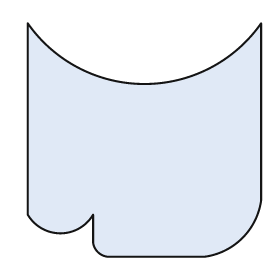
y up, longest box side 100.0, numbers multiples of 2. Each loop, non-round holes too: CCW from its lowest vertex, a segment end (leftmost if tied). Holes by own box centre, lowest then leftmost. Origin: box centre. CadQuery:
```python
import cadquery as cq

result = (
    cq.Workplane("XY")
    .moveTo(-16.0, -50.0)
    .lineTo(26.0, -50.0)
    .threePointArc((42.0, -42.0), (50.0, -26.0))
    .lineTo(50.0, 50.0)
    .threePointArc((0.0, 24.0), (-50.0, 50.0))
    .lineTo(-50.0, -32.0)
    .threePointArc((-36.0, -40.0), (-22.0, -32.0))
    .lineTo(-22.0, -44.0)
    .threePointArc((-20.0, -48.0), (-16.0, -50.0))
    .close()
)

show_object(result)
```